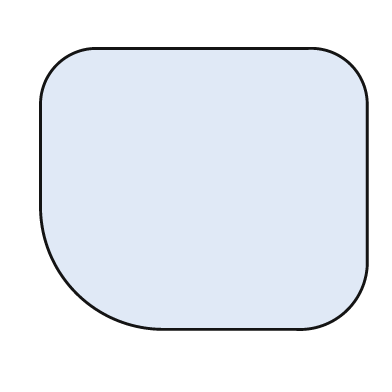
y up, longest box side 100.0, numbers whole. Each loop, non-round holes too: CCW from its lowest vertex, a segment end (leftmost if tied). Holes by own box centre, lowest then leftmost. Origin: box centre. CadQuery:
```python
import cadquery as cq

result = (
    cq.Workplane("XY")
    .moveTo(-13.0, -43.0)
    .lineTo(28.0, -43.0)
    .threePointArc((44.0, -37.0), (50.0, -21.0))
    .lineTo(50.0, 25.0)
    .threePointArc((45.0, 38.0), (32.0, 43.0))
    .lineTo(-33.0, 43.0)
    .threePointArc((-45.0, 38.0), (-50.0, 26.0))
    .lineTo(-50.0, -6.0)
    .threePointArc((-39.0, -32.0), (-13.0, -43.0))
    .close()
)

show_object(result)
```